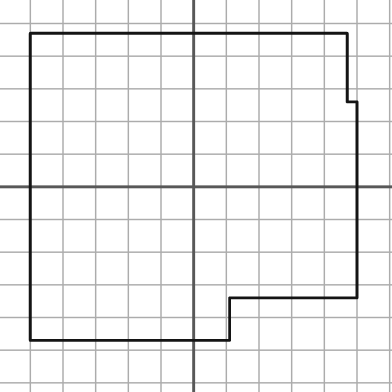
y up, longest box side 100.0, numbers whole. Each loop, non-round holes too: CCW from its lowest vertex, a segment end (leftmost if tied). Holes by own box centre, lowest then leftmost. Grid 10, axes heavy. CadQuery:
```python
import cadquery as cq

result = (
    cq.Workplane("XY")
    .moveTo(-50.0, -47.0)
    .lineTo(11.0, -47.0)
    .lineTo(11.0, -34.0)
    .lineTo(50.0, -34.0)
    .lineTo(50.0, 26.0)
    .lineTo(47.0, 26.0)
    .lineTo(47.0, 47.0)
    .lineTo(-50.0, 47.0)
    .close()
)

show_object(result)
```